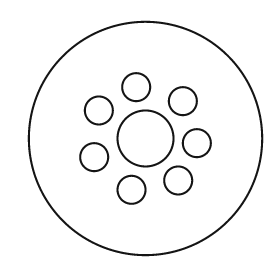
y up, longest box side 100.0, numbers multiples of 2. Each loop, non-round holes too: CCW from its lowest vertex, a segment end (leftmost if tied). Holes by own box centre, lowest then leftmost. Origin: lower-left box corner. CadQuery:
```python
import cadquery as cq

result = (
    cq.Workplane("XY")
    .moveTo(50.0, 50.0)
    .circle(50.0)
    .moveTo(44.0, 28.0)
    .circle(6.0)
    .moveTo(64.0, 32.0)
    .circle(6.0)
    .moveTo(28.0, 42.0)
    .circle(6.0)
    .moveTo(72.0, 48.0)
    .circle(6.0)
    .moveTo(50.0, 50.0)
    .circle(12.0)
    .moveTo(30.0, 62.0)
    .circle(6.0)
    .moveTo(66.0, 66.0)
    .circle(6.0)
    .moveTo(46.0, 72.0)
    .circle(6.0)
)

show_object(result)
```